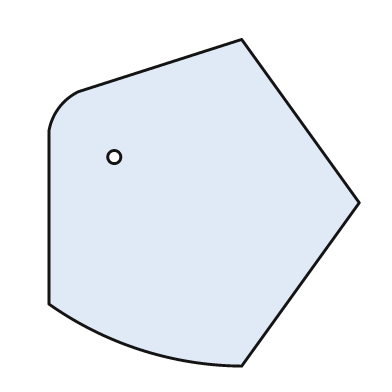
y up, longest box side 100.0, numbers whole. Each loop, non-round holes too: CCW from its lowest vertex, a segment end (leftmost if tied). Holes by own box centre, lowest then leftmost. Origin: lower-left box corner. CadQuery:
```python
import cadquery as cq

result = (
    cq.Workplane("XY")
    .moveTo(59.0, 0.0)
    .lineTo(95.0, 50.0)
    .lineTo(59.0, 100.0)
    .lineTo(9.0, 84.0)
    .threePointArc((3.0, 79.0), (0.0, 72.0))
    .lineTo(0.0, 19.0)
    .threePointArc((28.0, 5.0), (59.0, 0.0))
    .close()
    .moveTo(20.0, 64.0)
    .circle(2.0)
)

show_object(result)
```